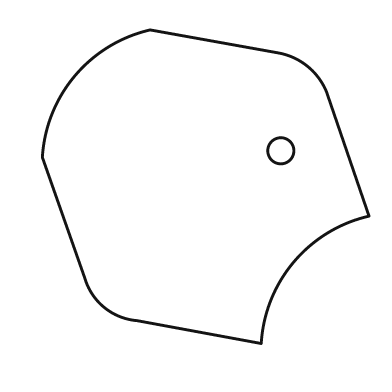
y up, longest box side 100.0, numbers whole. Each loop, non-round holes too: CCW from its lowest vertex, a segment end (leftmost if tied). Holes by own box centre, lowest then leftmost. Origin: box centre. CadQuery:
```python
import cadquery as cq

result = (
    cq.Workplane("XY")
    .moveTo(17.0, -48.0)
    .threePointArc((27.0, -23.0), (50.0, -9.0))
    .lineTo(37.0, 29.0)
    .threePointArc((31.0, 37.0), (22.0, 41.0))
    .lineTo(-17.0, 48.0)
    .threePointArc((-40.0, 34.0), (-50.0, 9.0))
    .lineTo(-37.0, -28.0)
    .threePointArc((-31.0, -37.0), (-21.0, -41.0))
    .close()
    .moveTo(23.0, 11.0)
    .circle(4.0)
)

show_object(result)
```